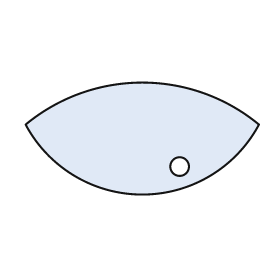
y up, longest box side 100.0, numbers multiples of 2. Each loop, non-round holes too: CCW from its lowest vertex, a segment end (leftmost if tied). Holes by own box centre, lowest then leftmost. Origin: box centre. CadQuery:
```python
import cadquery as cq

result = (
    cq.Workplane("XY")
    .moveTo(-50.0, 6.0)
    .threePointArc((0.0, -24.0), (50.0, 6.0))
    .threePointArc((0.0, 24.0), (-50.0, 6.0))
    .close()
    .moveTo(16.0, -12.0)
    .circle(4.0)
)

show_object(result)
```